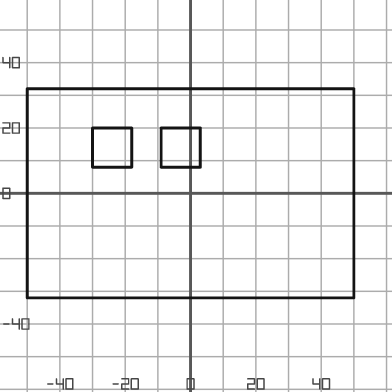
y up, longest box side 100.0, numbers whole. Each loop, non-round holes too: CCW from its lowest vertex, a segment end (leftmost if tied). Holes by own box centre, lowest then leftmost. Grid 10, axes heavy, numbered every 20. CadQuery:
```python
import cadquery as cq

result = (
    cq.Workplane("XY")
    .moveTo(-50.0, -32.0)
    .lineTo(50.0, -32.0)
    .lineTo(50.0, 32.0)
    .lineTo(-50.0, 32.0)
    .close()
    .moveTo(-30.0, 8.0)
    .lineTo(-18.0, 8.0)
    .lineTo(-18.0, 20.0)
    .lineTo(-30.0, 20.0)
    .close()
    .moveTo(-9.0, 8.0)
    .lineTo(3.0, 8.0)
    .lineTo(3.0, 20.0)
    .lineTo(-9.0, 20.0)
    .close()
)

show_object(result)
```